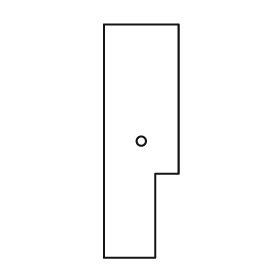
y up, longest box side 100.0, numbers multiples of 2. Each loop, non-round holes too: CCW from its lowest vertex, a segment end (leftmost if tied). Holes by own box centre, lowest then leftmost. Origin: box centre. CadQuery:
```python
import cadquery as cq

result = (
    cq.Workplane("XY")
    .moveTo(-16.0, -50.0)
    .lineTo(6.0, -50.0)
    .lineTo(6.0, -14.0)
    .lineTo(16.0, -14.0)
    .lineTo(16.0, 50.0)
    .lineTo(-16.0, 50.0)
    .close()
    .moveTo(0.0, 0.0)
    .circle(2.0)
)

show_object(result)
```